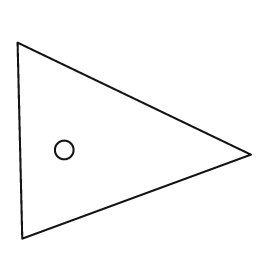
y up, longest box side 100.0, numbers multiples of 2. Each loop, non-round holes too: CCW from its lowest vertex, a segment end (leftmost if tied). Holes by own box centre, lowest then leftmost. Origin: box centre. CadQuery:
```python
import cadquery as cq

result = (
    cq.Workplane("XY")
    .moveTo(-48.0, -42.0)
    .lineTo(50.0, -6.0)
    .lineTo(-50.0, 42.0)
    .close()
    .moveTo(-30.0, -4.0)
    .circle(4.0)
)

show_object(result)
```